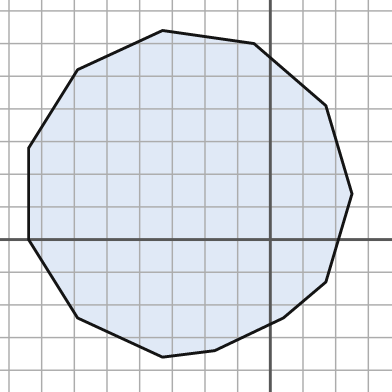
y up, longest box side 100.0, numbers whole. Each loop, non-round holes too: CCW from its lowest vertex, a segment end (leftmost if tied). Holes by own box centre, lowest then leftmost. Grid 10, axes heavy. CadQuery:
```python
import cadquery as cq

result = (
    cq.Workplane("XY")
    .moveTo(-33.0, -36.0)
    .lineTo(-17.0, -34.0)
    .lineTo(4.0, -24.0)
    .lineTo(17.0, -13.0)
    .lineTo(25.0, 14.0)
    .lineTo(17.0, 41.0)
    .lineTo(-5.0, 60.0)
    .lineTo(-33.0, 64.0)
    .lineTo(-59.0, 52.0)
    .lineTo(-74.0, 28.0)
    .lineTo(-74.0, 0.0)
    .lineTo(-59.0, -24.0)
    .close()
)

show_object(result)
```